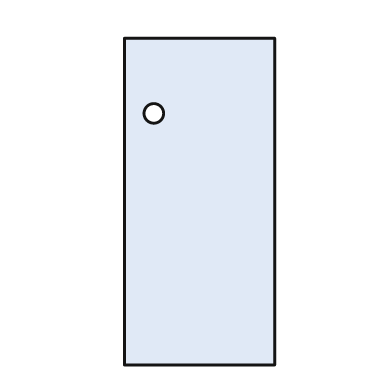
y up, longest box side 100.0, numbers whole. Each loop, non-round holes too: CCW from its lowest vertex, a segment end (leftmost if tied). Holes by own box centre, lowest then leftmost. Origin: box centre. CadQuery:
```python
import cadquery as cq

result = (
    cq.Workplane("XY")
    .moveTo(-23.0, -50.0)
    .lineTo(23.0, -50.0)
    .lineTo(23.0, 50.0)
    .lineTo(-23.0, 50.0)
    .close()
    .moveTo(-14.0, 27.0)
    .circle(3.0)
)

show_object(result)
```